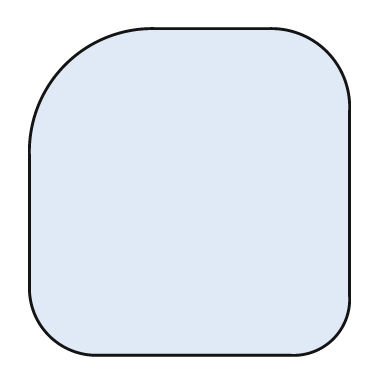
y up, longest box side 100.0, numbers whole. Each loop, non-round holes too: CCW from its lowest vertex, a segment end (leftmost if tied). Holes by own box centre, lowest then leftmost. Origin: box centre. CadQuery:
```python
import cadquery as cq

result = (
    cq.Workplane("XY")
    .moveTo(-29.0, -50.0)
    .lineTo(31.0, -50.0)
    .threePointArc((44.0, -45.0), (49.0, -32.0))
    .lineTo(49.0, 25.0)
    .threePointArc((42.0, 43.0), (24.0, 50.0))
    .lineTo(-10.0, 50.0)
    .threePointArc((-38.0, 39.0), (-49.0, 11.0))
    .lineTo(-49.0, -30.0)
    .threePointArc((-43.0, -44.0), (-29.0, -50.0))
    .close()
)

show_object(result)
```